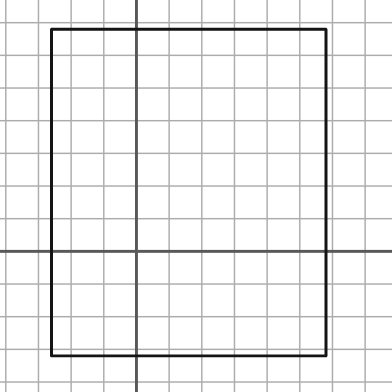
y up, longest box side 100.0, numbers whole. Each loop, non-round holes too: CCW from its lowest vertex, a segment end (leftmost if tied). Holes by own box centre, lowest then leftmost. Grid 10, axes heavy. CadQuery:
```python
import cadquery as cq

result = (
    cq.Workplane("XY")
    .moveTo(-26.0, -32.0)
    .lineTo(58.0, -32.0)
    .lineTo(58.0, 68.0)
    .lineTo(-26.0, 68.0)
    .close()
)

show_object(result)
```